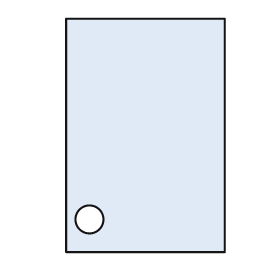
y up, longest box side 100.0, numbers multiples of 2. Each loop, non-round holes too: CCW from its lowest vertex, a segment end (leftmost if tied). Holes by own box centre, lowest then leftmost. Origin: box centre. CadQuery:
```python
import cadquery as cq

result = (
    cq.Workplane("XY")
    .moveTo(-34.0, -50.0)
    .lineTo(34.0, -50.0)
    .lineTo(34.0, 50.0)
    .lineTo(-34.0, 50.0)
    .close()
    .moveTo(-24.0, -36.0)
    .circle(6.0)
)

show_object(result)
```